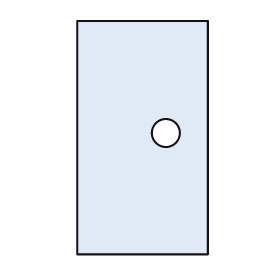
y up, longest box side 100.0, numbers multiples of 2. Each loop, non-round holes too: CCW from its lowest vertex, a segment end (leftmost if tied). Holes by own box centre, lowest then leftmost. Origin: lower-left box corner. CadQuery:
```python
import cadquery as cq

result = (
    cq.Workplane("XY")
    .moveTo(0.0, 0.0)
    .lineTo(56.0, 0.0)
    .lineTo(56.0, 100.0)
    .lineTo(0.0, 100.0)
    .close()
    .moveTo(38.0, 52.0)
    .circle(6.0)
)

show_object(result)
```